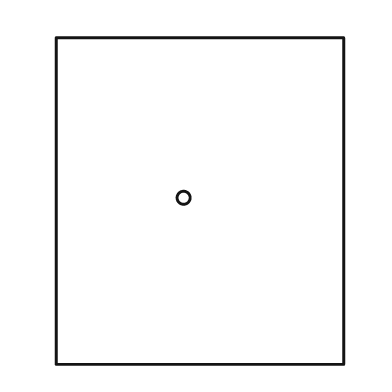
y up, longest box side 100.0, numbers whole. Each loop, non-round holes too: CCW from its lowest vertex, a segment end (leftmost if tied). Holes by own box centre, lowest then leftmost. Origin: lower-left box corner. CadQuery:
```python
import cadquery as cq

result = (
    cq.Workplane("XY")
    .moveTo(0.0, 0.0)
    .lineTo(88.0, 0.0)
    .lineTo(88.0, 100.0)
    .lineTo(0.0, 100.0)
    .close()
    .moveTo(39.0, 51.0)
    .circle(2.0)
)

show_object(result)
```